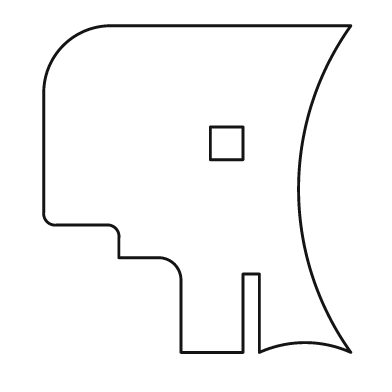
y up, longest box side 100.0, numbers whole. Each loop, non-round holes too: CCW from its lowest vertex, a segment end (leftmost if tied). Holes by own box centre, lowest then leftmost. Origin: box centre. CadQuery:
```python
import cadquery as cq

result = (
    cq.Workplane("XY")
    .moveTo(-5.0, -50.0)
    .lineTo(14.0, -50.0)
    .lineTo(14.0, -26.0)
    .lineTo(19.0, -26.0)
    .lineTo(19.0, -50.0)
    .threePointArc((33.0, -47.0), (47.0, -50.0))
    .threePointArc((31.0, 0.0), (47.0, 50.0))
    .lineTo(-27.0, 50.0)
    .threePointArc((-41.0, 44.0), (-47.0, 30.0))
    .lineTo(-47.0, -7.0)
    .threePointArc((-46.0, -10.0), (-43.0, -11.0))
    .lineTo(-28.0, -11.0)
    .threePointArc((-25.0, -12.0), (-24.0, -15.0))
    .lineTo(-24.0, -21.0)
    .lineTo(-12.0, -21.0)
    .threePointArc((-7.0, -23.0), (-5.0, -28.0))
    .close()
    .moveTo(4.0, 9.0)
    .lineTo(14.0, 9.0)
    .lineTo(14.0, 19.0)
    .lineTo(4.0, 19.0)
    .close()
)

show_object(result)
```